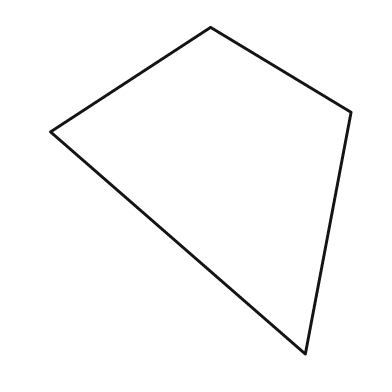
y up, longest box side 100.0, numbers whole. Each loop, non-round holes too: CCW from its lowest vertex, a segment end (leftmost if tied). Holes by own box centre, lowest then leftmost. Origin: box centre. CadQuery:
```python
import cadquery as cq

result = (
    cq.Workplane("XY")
    .moveTo(32.0, -50.0)
    .lineTo(46.0, 24.0)
    .lineTo(3.0, 50.0)
    .lineTo(-46.0, 18.0)
    .close()
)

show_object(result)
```